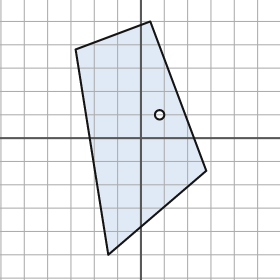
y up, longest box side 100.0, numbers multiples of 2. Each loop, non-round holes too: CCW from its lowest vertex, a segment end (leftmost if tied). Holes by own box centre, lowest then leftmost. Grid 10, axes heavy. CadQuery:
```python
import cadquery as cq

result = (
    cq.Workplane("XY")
    .moveTo(-14.0, -50.0)
    .lineTo(28.0, -14.0)
    .lineTo(4.0, 50.0)
    .lineTo(-28.0, 38.0)
    .close()
    .moveTo(8.0, 10.0)
    .circle(2.0)
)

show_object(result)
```